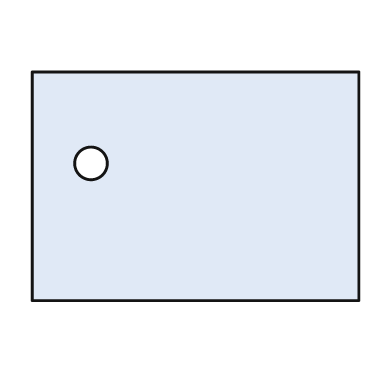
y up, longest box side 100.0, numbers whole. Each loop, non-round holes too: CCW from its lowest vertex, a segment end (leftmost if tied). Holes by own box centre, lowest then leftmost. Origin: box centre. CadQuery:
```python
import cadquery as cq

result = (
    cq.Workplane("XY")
    .moveTo(-50.0, -35.0)
    .lineTo(50.0, -35.0)
    .lineTo(50.0, 35.0)
    .lineTo(-50.0, 35.0)
    .close()
    .moveTo(-32.0, 7.0)
    .circle(5.0)
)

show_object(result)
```